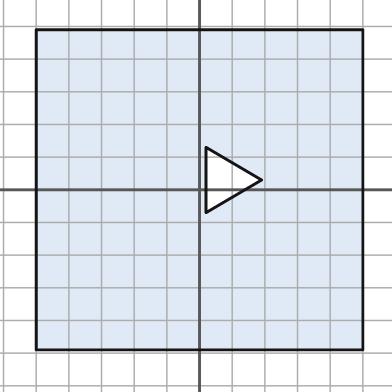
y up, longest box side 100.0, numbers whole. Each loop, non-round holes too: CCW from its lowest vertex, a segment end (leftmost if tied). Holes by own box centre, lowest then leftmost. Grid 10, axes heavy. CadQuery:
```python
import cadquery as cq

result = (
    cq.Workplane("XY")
    .moveTo(-50.0, -49.0)
    .lineTo(50.0, -49.0)
    .lineTo(50.0, 49.0)
    .lineTo(-50.0, 49.0)
    .close()
    .moveTo(2.0, -7.0)
    .lineTo(19.0, 3.0)
    .lineTo(2.0, 13.0)
    .close()
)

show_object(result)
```